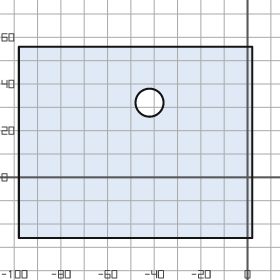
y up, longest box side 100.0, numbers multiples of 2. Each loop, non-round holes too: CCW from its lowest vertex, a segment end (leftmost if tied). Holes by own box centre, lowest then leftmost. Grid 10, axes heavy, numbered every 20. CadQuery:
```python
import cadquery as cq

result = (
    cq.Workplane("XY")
    .moveTo(-98.0, -26.0)
    .lineTo(2.0, -26.0)
    .lineTo(2.0, 56.0)
    .lineTo(-98.0, 56.0)
    .close()
    .moveTo(-42.0, 32.0)
    .circle(6.0)
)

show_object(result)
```